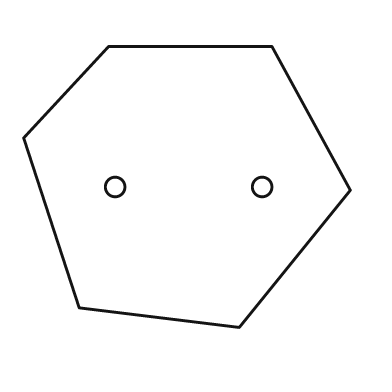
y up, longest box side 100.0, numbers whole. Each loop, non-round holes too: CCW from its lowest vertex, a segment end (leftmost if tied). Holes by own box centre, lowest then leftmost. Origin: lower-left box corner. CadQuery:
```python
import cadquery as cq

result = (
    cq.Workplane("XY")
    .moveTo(66.0, 0.0)
    .lineTo(100.0, 42.0)
    .lineTo(76.0, 86.0)
    .lineTo(26.0, 86.0)
    .lineTo(0.0, 58.0)
    .lineTo(17.0, 6.0)
    .close()
    .moveTo(28.0, 43.0)
    .circle(3.0)
    .moveTo(73.0, 43.0)
    .circle(3.0)
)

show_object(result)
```